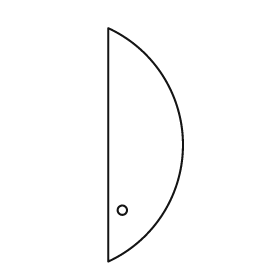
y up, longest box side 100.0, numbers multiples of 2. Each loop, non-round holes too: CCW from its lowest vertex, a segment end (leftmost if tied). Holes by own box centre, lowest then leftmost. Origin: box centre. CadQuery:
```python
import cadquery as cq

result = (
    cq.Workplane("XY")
    .moveTo(-16.0, -50.0)
    .threePointArc((16.0, 0.0), (-16.0, 50.0))
    .close()
    .moveTo(-10.0, -28.0)
    .circle(2.0)
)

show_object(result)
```